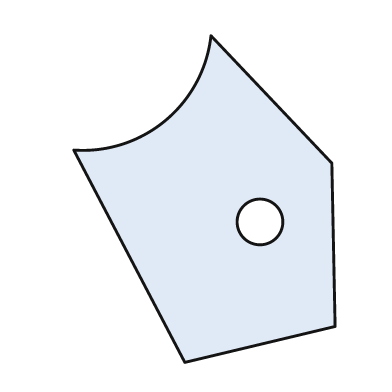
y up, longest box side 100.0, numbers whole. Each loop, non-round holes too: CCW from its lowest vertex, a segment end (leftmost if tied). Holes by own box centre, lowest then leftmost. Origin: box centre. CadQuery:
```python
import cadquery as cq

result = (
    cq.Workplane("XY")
    .moveTo(-6.0, -50.0)
    .lineTo(40.0, -39.0)
    .lineTo(39.0, 11.0)
    .lineTo(2.0, 50.0)
    .threePointArc((-12.0, 24.0), (-40.0, 15.0))
    .close()
    .moveTo(17.0, -7.0)
    .circle(7.0)
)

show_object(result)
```